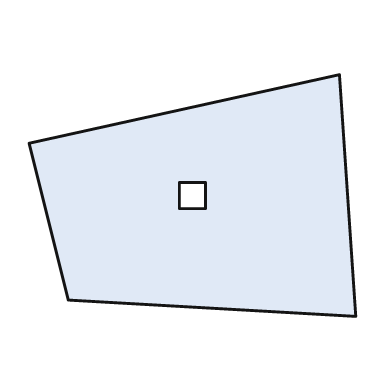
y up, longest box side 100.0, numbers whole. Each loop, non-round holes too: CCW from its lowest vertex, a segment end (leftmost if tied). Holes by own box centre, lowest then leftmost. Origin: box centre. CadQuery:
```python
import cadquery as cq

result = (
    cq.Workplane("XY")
    .moveTo(50.0, -37.0)
    .lineTo(45.0, 37.0)
    .lineTo(-50.0, 16.0)
    .lineTo(-38.0, -32.0)
    .close()
    .moveTo(-4.0, -4.0)
    .lineTo(4.0, -4.0)
    .lineTo(4.0, 4.0)
    .lineTo(-4.0, 4.0)
    .close()
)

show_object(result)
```